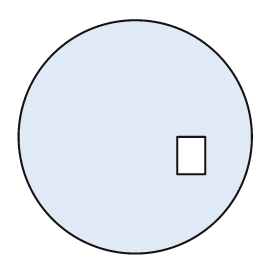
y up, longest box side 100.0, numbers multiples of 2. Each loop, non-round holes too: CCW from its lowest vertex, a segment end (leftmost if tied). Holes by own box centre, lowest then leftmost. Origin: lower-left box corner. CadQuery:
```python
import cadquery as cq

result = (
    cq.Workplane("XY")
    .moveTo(50.0, 50.0)
    .circle(50.0)
    .moveTo(68.0, 34.0)
    .lineTo(80.0, 34.0)
    .lineTo(80.0, 50.0)
    .lineTo(68.0, 50.0)
    .close()
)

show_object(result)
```